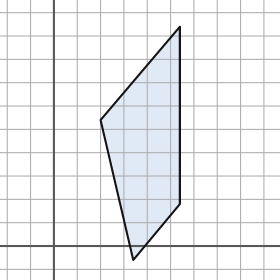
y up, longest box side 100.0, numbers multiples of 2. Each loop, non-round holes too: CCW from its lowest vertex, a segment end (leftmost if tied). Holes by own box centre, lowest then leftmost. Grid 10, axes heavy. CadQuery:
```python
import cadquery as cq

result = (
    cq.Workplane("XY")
    .moveTo(34.0, -6.0)
    .lineTo(54.0, 18.0)
    .lineTo(54.0, 94.0)
    .lineTo(20.0, 54.0)
    .close()
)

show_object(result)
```